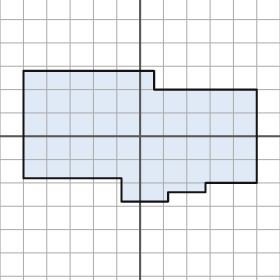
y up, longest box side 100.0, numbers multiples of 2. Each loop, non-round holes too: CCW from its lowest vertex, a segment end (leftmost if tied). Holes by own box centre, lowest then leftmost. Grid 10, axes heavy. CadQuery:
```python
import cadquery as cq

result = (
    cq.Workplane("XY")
    .moveTo(-8.0, -28.0)
    .lineTo(12.0, -28.0)
    .lineTo(12.0, -24.0)
    .lineTo(28.0, -24.0)
    .lineTo(28.0, -20.0)
    .lineTo(50.0, -20.0)
    .lineTo(50.0, 20.0)
    .lineTo(6.0, 20.0)
    .lineTo(6.0, 28.0)
    .lineTo(-50.0, 28.0)
    .lineTo(-50.0, -18.0)
    .lineTo(-8.0, -18.0)
    .close()
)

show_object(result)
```